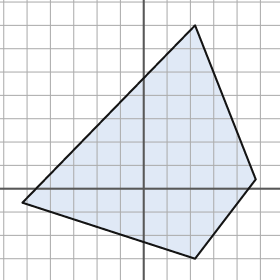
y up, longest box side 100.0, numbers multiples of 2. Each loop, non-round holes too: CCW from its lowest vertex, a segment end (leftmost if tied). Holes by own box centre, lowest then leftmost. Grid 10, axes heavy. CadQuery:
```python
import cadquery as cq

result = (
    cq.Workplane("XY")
    .moveTo(22.0, -30.0)
    .lineTo(48.0, 4.0)
    .lineTo(22.0, 70.0)
    .lineTo(-52.0, -6.0)
    .close()
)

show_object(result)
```